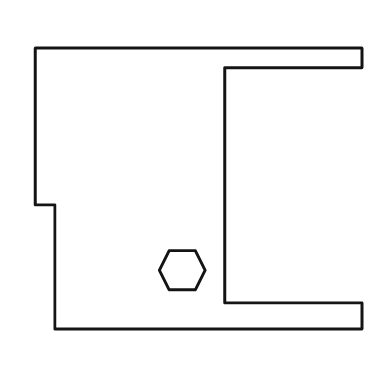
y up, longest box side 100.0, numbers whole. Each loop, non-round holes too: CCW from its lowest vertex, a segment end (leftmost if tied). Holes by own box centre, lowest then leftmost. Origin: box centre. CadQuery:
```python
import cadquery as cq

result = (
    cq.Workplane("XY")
    .moveTo(-44.0, -43.0)
    .lineTo(50.0, -43.0)
    .lineTo(50.0, -35.0)
    .lineTo(8.0, -35.0)
    .lineTo(8.0, 37.0)
    .lineTo(50.0, 37.0)
    .lineTo(50.0, 43.0)
    .lineTo(-50.0, 43.0)
    .lineTo(-50.0, -5.0)
    .lineTo(-44.0, -5.0)
    .close()
    .moveTo(-9.0, -31.0)
    .lineTo(-1.0, -31.0)
    .lineTo(2.0, -25.0)
    .lineTo(-1.0, -19.0)
    .lineTo(-9.0, -19.0)
    .lineTo(-12.0, -25.0)
    .close()
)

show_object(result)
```